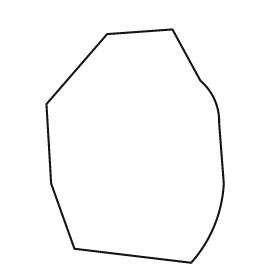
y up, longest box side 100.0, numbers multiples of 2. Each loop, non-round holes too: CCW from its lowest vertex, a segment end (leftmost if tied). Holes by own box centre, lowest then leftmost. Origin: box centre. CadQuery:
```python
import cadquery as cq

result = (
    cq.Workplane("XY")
    .moveTo(24.0, -50.0)
    .threePointArc((34.0, -34.0), (38.0, -16.0))
    .lineTo(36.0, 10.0)
    .threePointArc((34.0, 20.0), (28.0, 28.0))
    .lineTo(16.0, 50.0)
    .lineTo(-12.0, 48.0)
    .lineTo(-38.0, 18.0)
    .lineTo(-36.0, -16.0)
    .lineTo(-26.0, -44.0)
    .close()
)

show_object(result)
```